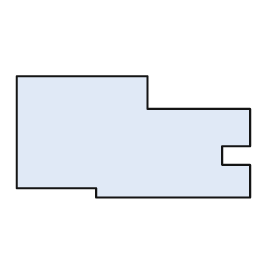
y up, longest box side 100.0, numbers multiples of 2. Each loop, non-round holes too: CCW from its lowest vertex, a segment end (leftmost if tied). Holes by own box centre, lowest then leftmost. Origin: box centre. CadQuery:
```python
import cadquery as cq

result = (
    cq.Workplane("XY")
    .moveTo(-16.0, -26.0)
    .lineTo(50.0, -26.0)
    .lineTo(50.0, -12.0)
    .lineTo(38.0, -12.0)
    .lineTo(38.0, -4.0)
    .lineTo(50.0, -4.0)
    .lineTo(50.0, 12.0)
    .lineTo(6.0, 12.0)
    .lineTo(6.0, 26.0)
    .lineTo(-50.0, 26.0)
    .lineTo(-50.0, -22.0)
    .lineTo(-16.0, -22.0)
    .close()
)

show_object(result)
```